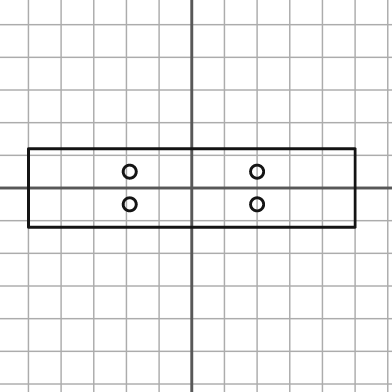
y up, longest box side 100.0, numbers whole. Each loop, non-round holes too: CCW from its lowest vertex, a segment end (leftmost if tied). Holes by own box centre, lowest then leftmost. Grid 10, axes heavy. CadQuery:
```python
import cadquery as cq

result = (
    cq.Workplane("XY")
    .moveTo(-50.0, -12.0)
    .lineTo(50.0, -12.0)
    .lineTo(50.0, 12.0)
    .lineTo(-50.0, 12.0)
    .close()
    .moveTo(-19.0, -5.0)
    .circle(2.0)
    .moveTo(20.0, -5.0)
    .circle(2.0)
    .moveTo(-19.0, 5.0)
    .circle(2.0)
    .moveTo(20.0, 5.0)
    .circle(2.0)
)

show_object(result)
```